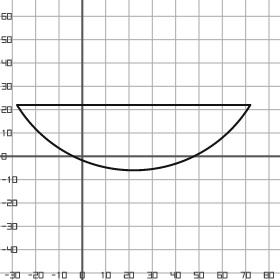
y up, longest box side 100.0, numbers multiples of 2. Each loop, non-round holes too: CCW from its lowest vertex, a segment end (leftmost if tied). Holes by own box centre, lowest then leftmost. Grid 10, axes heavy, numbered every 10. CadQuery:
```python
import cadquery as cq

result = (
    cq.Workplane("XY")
    .moveTo(-28.0, 22.0)
    .threePointArc((22.0, -6.0), (72.0, 22.0))
    .close()
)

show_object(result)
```